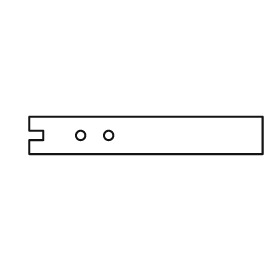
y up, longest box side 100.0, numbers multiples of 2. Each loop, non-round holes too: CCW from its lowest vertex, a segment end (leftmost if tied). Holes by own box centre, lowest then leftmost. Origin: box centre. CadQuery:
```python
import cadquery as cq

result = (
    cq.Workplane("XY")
    .moveTo(-50.0, -8.0)
    .lineTo(50.0, -8.0)
    .lineTo(50.0, 8.0)
    .lineTo(-50.0, 8.0)
    .lineTo(-50.0, 2.0)
    .lineTo(-44.0, 2.0)
    .lineTo(-44.0, -2.0)
    .lineTo(-50.0, -2.0)
    .close()
    .moveTo(-28.0, 0.0)
    .circle(2.0)
    .moveTo(-16.0, 0.0)
    .circle(2.0)
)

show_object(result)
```